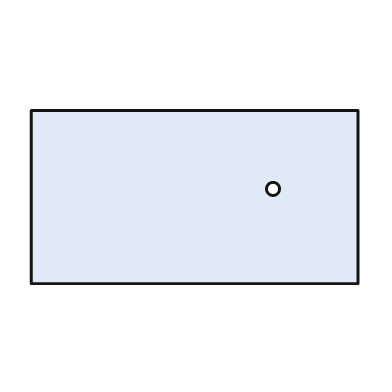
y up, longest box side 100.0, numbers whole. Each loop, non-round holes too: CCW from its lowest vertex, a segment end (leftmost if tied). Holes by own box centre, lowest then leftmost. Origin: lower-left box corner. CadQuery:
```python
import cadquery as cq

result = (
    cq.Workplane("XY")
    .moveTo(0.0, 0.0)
    .lineTo(100.0, 0.0)
    .lineTo(100.0, 53.0)
    .lineTo(0.0, 53.0)
    .close()
    .moveTo(74.0, 29.0)
    .circle(2.0)
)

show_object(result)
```